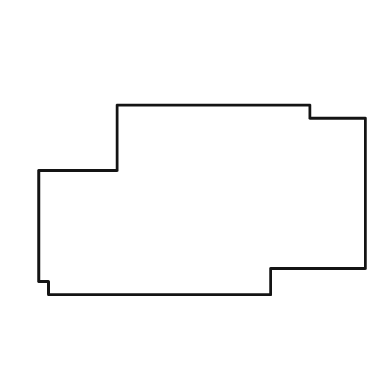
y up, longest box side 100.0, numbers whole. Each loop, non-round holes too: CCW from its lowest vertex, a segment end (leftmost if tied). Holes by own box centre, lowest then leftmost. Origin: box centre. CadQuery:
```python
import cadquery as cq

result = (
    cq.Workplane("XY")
    .moveTo(-47.0, -29.0)
    .lineTo(21.0, -29.0)
    .lineTo(21.0, -21.0)
    .lineTo(50.0, -21.0)
    .lineTo(50.0, 25.0)
    .lineTo(33.0, 25.0)
    .lineTo(33.0, 29.0)
    .lineTo(-26.0, 29.0)
    .lineTo(-26.0, 9.0)
    .lineTo(-50.0, 9.0)
    .lineTo(-50.0, -25.0)
    .lineTo(-47.0, -25.0)
    .close()
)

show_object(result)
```